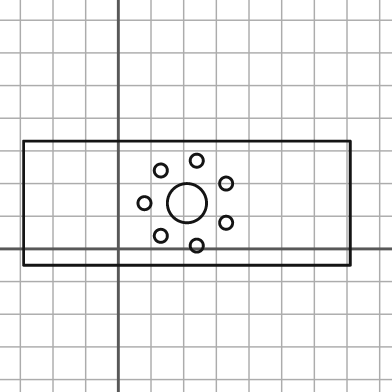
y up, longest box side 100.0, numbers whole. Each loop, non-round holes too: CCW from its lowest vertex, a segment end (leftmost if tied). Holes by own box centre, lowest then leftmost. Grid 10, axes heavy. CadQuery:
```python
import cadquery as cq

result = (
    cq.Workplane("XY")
    .moveTo(-29.0, -5.0)
    .lineTo(71.0, -5.0)
    .lineTo(71.0, 33.0)
    .lineTo(-29.0, 33.0)
    .close()
    .moveTo(24.0, 1.0)
    .circle(2.0)
    .moveTo(13.0, 4.0)
    .circle(2.0)
    .moveTo(33.0, 8.0)
    .circle(2.0)
    .moveTo(8.0, 14.0)
    .circle(2.0)
    .moveTo(21.0, 14.0)
    .circle(6.0)
    .moveTo(33.0, 20.0)
    .circle(2.0)
    .moveTo(13.0, 24.0)
    .circle(2.0)
    .moveTo(24.0, 27.0)
    .circle(2.0)
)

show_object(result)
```